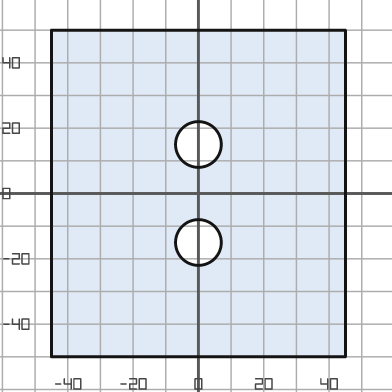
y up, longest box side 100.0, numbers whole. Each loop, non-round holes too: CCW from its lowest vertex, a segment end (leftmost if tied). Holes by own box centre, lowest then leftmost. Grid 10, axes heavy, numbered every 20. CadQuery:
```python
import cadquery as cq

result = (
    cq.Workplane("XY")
    .moveTo(-45.0, -50.0)
    .lineTo(45.0, -50.0)
    .lineTo(45.0, 50.0)
    .lineTo(-45.0, 50.0)
    .close()
    .moveTo(0.0, -15.0)
    .circle(7.0)
    .moveTo(0.0, 15.0)
    .circle(7.0)
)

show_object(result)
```